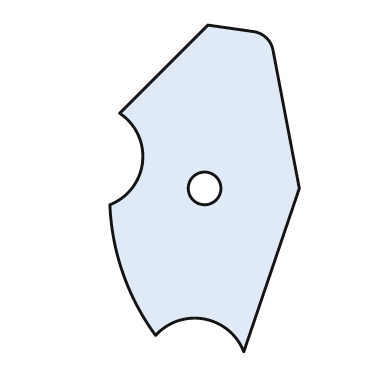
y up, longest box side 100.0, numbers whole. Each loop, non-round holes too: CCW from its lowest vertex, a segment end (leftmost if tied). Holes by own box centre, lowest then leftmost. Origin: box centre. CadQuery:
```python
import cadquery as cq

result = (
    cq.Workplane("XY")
    .moveTo(12.0, -50.0)
    .lineTo(29.0, 0.0)
    .lineTo(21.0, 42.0)
    .threePointArc((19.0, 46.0), (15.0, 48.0))
    .lineTo(1.0, 50.0)
    .lineTo(-26.0, 23.0)
    .threePointArc((-19.0, 8.0), (-29.0, -5.0))
    .threePointArc((-25.0, -26.0), (-15.0, -45.0))
    .threePointArc((0.0, -40.0), (12.0, -50.0))
    .close()
    .moveTo(0.0, 0.0)
    .circle(5.0)
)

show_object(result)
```